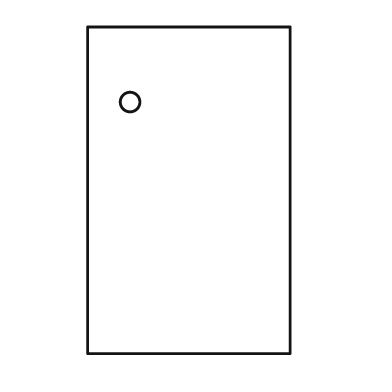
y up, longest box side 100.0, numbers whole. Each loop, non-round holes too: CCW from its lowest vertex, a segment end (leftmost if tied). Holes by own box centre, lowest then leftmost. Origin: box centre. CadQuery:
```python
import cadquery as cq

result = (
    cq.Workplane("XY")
    .moveTo(-31.0, -50.0)
    .lineTo(31.0, -50.0)
    .lineTo(31.0, 50.0)
    .lineTo(-31.0, 50.0)
    .close()
    .moveTo(-18.0, 27.0)
    .circle(3.0)
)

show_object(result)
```